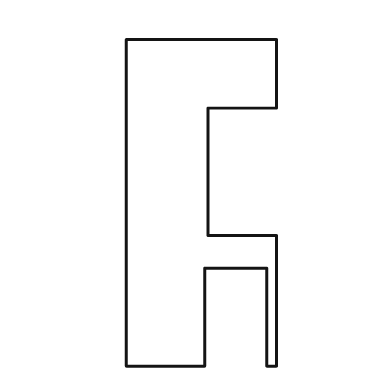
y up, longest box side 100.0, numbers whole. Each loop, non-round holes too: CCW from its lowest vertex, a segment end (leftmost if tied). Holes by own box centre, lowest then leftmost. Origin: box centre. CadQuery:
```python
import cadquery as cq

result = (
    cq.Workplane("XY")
    .moveTo(-23.0, -50.0)
    .lineTo(1.0, -50.0)
    .lineTo(1.0, -20.0)
    .lineTo(20.0, -20.0)
    .lineTo(20.0, -50.0)
    .lineTo(23.0, -50.0)
    .lineTo(23.0, -10.0)
    .lineTo(2.0, -10.0)
    .lineTo(2.0, 29.0)
    .lineTo(23.0, 29.0)
    .lineTo(23.0, 50.0)
    .lineTo(-23.0, 50.0)
    .close()
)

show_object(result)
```